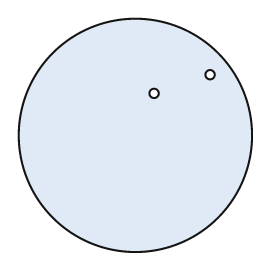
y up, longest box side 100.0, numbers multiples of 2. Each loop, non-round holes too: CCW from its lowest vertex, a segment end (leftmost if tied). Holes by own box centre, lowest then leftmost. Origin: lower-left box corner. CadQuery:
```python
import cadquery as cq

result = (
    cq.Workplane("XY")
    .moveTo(50.0, 50.0)
    .circle(50.0)
    .moveTo(58.0, 68.0)
    .circle(2.0)
    .moveTo(82.0, 76.0)
    .circle(2.0)
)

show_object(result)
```